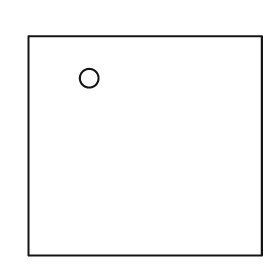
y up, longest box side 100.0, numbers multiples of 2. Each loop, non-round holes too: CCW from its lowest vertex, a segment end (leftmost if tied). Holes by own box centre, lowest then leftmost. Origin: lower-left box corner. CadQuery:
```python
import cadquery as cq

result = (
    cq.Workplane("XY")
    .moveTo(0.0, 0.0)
    .lineTo(100.0, 0.0)
    .lineTo(100.0, 94.0)
    .lineTo(0.0, 94.0)
    .close()
    .moveTo(26.0, 76.0)
    .circle(4.0)
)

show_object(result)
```